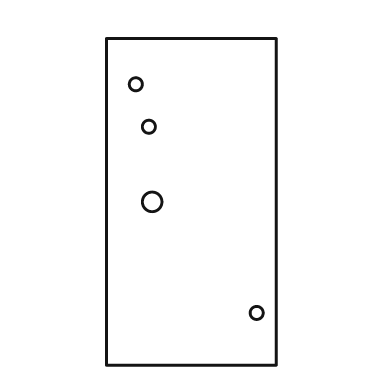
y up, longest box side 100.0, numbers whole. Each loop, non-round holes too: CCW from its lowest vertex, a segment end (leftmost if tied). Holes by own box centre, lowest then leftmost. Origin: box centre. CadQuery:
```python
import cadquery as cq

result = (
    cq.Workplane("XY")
    .moveTo(-26.0, -50.0)
    .lineTo(26.0, -50.0)
    .lineTo(26.0, 50.0)
    .lineTo(-26.0, 50.0)
    .close()
    .moveTo(20.0, -34.0)
    .circle(2.0)
    .moveTo(-12.0, 0.0)
    .circle(3.0)
    .moveTo(-13.0, 23.0)
    .circle(2.0)
    .moveTo(-17.0, 36.0)
    .circle(2.0)
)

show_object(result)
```